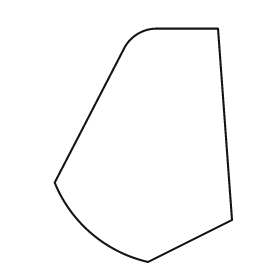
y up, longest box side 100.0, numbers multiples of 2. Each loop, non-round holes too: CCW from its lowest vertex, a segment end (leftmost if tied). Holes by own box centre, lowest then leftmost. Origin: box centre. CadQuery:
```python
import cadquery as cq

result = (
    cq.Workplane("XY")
    .moveTo(2.0, -50.0)
    .lineTo(38.0, -32.0)
    .lineTo(32.0, 50.0)
    .lineTo(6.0, 50.0)
    .threePointArc((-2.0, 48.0), (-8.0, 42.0))
    .lineTo(-38.0, -16.0)
    .threePointArc((-22.0, -38.0), (2.0, -50.0))
    .close()
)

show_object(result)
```